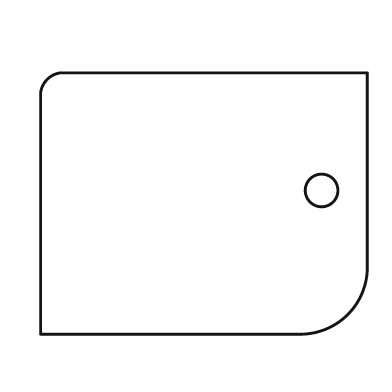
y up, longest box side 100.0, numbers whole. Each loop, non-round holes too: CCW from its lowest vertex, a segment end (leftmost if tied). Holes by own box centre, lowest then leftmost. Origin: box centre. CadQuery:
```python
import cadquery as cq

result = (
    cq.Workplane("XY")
    .moveTo(-50.0, -40.0)
    .lineTo(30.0, -40.0)
    .threePointArc((44.0, -34.0), (50.0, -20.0))
    .lineTo(50.0, 40.0)
    .lineTo(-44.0, 40.0)
    .threePointArc((-48.0, 38.0), (-50.0, 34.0))
    .close()
    .moveTo(36.0, 4.0)
    .circle(5.0)
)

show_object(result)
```